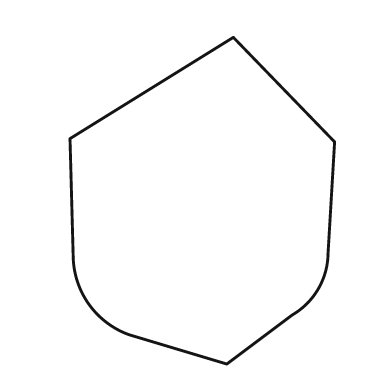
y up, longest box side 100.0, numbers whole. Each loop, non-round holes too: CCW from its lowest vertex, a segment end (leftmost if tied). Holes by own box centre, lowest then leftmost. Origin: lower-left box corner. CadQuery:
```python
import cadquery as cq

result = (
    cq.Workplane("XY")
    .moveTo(48.0, 0.0)
    .lineTo(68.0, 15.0)
    .threePointArc((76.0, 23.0), (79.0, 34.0))
    .lineTo(81.0, 68.0)
    .lineTo(50.0, 100.0)
    .lineTo(0.0, 69.0)
    .lineTo(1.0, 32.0)
    .threePointArc((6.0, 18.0), (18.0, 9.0))
    .close()
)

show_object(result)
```